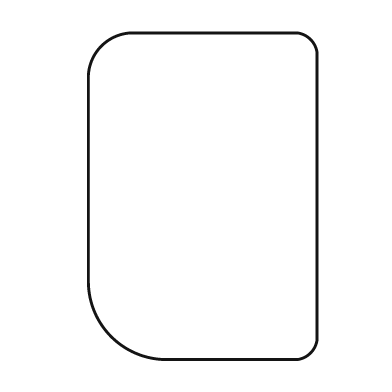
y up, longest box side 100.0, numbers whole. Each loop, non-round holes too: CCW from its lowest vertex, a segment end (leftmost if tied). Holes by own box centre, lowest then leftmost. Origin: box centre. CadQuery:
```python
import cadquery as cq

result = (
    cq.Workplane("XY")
    .moveTo(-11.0, -50.0)
    .lineTo(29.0, -50.0)
    .threePointArc((33.0, -48.0), (35.0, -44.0))
    .lineTo(35.0, 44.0)
    .threePointArc((33.0, 48.0), (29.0, 50.0))
    .lineTo(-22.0, 50.0)
    .threePointArc((-31.0, 46.0), (-35.0, 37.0))
    .lineTo(-35.0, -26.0)
    .threePointArc((-28.0, -43.0), (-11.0, -50.0))
    .close()
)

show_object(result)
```